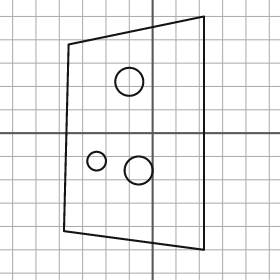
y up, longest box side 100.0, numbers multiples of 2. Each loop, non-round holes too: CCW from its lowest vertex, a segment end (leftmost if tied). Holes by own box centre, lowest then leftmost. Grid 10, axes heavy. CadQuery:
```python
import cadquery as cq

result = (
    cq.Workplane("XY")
    .moveTo(22.0, -50.0)
    .lineTo(22.0, 50.0)
    .lineTo(-36.0, 38.0)
    .lineTo(-38.0, -42.0)
    .close()
    .moveTo(-6.0, -16.0)
    .circle(6.0)
    .moveTo(-24.0, -12.0)
    .circle(4.0)
    .moveTo(-10.0, 22.0)
    .circle(6.0)
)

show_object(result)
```